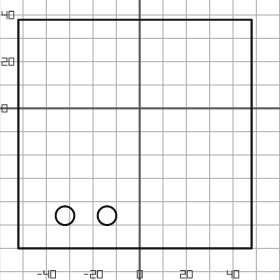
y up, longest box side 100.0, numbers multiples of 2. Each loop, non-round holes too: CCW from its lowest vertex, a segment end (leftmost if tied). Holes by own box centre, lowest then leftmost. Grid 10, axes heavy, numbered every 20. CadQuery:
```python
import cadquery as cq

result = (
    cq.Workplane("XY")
    .moveTo(-52.0, -60.0)
    .lineTo(48.0, -60.0)
    .lineTo(48.0, 38.0)
    .lineTo(-52.0, 38.0)
    .close()
    .moveTo(-32.0, -46.0)
    .circle(4.0)
    .moveTo(-14.0, -46.0)
    .circle(4.0)
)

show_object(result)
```